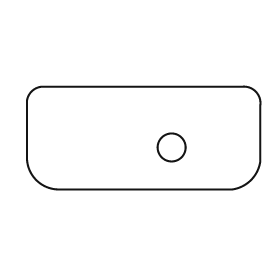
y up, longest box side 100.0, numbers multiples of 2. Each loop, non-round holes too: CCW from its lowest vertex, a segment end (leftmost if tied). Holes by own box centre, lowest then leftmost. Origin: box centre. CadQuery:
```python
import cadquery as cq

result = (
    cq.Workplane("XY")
    .moveTo(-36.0, -22.0)
    .lineTo(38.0, -22.0)
    .threePointArc((46.0, -18.0), (50.0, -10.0))
    .lineTo(50.0, 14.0)
    .threePointArc((48.0, 20.0), (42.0, 22.0))
    .lineTo(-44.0, 22.0)
    .threePointArc((-48.0, 20.0), (-50.0, 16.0))
    .lineTo(-50.0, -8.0)
    .threePointArc((-46.0, -18.0), (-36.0, -22.0))
    .close()
    .moveTo(12.0, -4.0)
    .circle(6.0)
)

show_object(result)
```